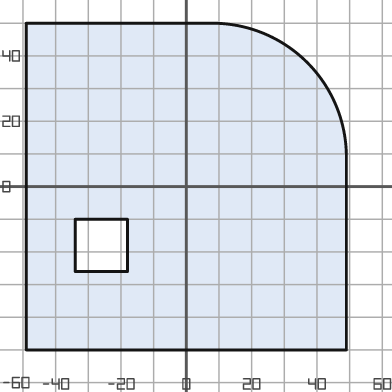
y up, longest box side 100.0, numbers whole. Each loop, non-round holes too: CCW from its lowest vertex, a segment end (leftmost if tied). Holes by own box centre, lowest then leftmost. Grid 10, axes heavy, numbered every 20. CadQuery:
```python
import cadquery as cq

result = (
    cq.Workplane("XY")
    .moveTo(-49.0, -50.0)
    .lineTo(49.0, -50.0)
    .lineTo(49.0, 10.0)
    .threePointArc((37.0, 38.0), (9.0, 50.0))
    .lineTo(-49.0, 50.0)
    .close()
    .moveTo(-34.0, -26.0)
    .lineTo(-18.0, -26.0)
    .lineTo(-18.0, -10.0)
    .lineTo(-34.0, -10.0)
    .close()
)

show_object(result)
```